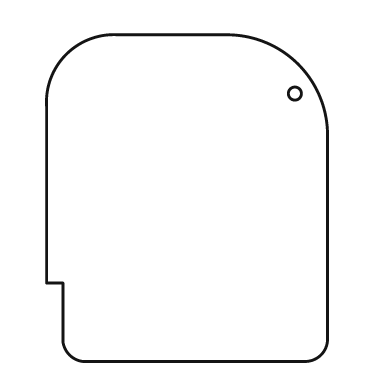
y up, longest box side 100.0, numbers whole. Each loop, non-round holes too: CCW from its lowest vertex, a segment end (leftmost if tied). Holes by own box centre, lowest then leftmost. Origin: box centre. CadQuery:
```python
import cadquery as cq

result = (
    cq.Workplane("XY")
    .moveTo(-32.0, -50.0)
    .lineTo(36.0, -50.0)
    .threePointArc((41.0, -48.0), (43.0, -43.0))
    .lineTo(43.0, 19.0)
    .threePointArc((34.0, 41.0), (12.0, 50.0))
    .lineTo(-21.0, 50.0)
    .threePointArc((-37.0, 44.0), (-43.0, 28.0))
    .lineTo(-43.0, -26.0)
    .lineTo(-38.0, -26.0)
    .lineTo(-38.0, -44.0)
    .threePointArc((-36.0, -48.0), (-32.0, -50.0))
    .close()
    .moveTo(33.0, 32.0)
    .circle(2.0)
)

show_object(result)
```